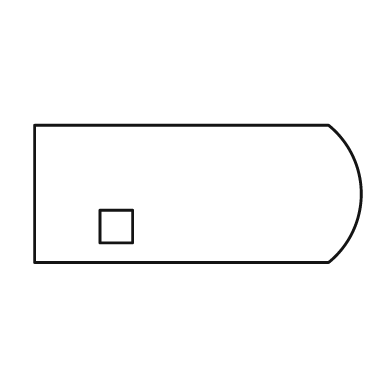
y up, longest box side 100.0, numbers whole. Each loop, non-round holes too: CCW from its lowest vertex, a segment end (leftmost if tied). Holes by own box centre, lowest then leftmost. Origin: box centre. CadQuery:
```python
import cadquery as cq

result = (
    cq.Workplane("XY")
    .moveTo(-50.0, -21.0)
    .lineTo(40.0, -21.0)
    .threePointArc((50.0, 0.0), (40.0, 21.0))
    .lineTo(-50.0, 21.0)
    .close()
    .moveTo(-30.0, -15.0)
    .lineTo(-20.0, -15.0)
    .lineTo(-20.0, -5.0)
    .lineTo(-30.0, -5.0)
    .close()
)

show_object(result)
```